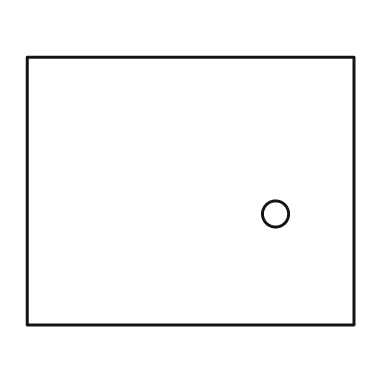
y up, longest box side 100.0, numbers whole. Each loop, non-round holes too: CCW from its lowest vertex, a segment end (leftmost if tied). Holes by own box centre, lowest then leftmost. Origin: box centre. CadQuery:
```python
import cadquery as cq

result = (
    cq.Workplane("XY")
    .moveTo(-50.0, -41.0)
    .lineTo(50.0, -41.0)
    .lineTo(50.0, 41.0)
    .lineTo(-50.0, 41.0)
    .close()
    .moveTo(26.0, -7.0)
    .circle(4.0)
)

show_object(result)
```